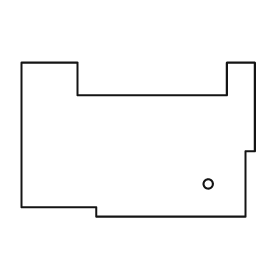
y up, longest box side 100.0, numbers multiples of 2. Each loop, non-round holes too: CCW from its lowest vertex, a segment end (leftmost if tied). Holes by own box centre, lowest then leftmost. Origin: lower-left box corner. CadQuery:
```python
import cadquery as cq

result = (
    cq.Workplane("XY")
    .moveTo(32.0, 0.0)
    .lineTo(96.0, 0.0)
    .lineTo(96.0, 28.0)
    .lineTo(100.0, 28.0)
    .lineTo(100.0, 66.0)
    .lineTo(88.0, 66.0)
    .lineTo(88.0, 52.0)
    .lineTo(24.0, 52.0)
    .lineTo(24.0, 66.0)
    .lineTo(0.0, 66.0)
    .lineTo(0.0, 4.0)
    .lineTo(32.0, 4.0)
    .close()
    .moveTo(80.0, 14.0)
    .circle(2.0)
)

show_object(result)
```